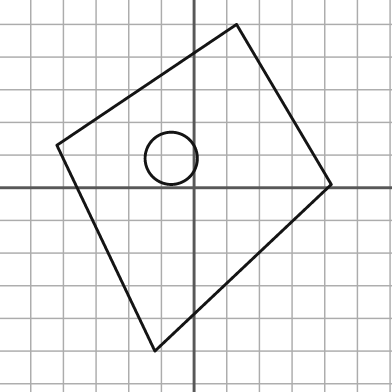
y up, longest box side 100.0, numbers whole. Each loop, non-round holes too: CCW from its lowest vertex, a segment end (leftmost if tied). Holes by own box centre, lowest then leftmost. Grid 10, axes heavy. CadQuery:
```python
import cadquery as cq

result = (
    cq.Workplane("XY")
    .moveTo(-12.0, -50.0)
    .lineTo(42.0, 1.0)
    .lineTo(13.0, 50.0)
    .lineTo(-42.0, 13.0)
    .close()
    .moveTo(-7.0, 9.0)
    .circle(8.0)
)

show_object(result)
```